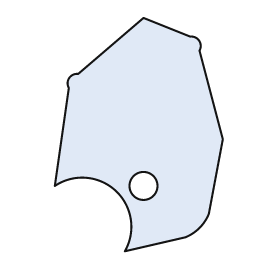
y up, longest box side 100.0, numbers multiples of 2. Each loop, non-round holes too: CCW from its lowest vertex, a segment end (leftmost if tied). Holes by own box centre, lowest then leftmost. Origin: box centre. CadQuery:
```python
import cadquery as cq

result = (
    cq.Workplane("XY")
    .moveTo(-6.0, -50.0)
    .lineTo(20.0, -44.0)
    .threePointArc((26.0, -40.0), (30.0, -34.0))
    .lineTo(36.0, -2.0)
    .lineTo(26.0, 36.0)
    .threePointArc((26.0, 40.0), (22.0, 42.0))
    .lineTo(2.0, 50.0)
    .lineTo(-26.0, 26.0)
    .threePointArc((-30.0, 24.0), (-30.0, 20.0))
    .lineTo(-36.0, -22.0)
    .threePointArc((-10.0, -24.0), (-6.0, -50.0))
    .close()
    .moveTo(2.0, -22.0)
    .circle(6.0)
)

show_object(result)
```